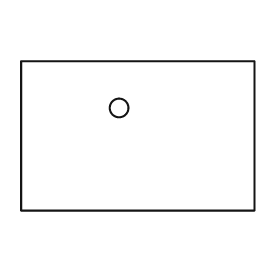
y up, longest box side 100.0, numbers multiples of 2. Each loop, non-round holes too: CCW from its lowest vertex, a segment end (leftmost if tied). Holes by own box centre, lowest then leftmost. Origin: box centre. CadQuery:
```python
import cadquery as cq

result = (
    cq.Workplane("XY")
    .moveTo(-50.0, -32.0)
    .lineTo(50.0, -32.0)
    .lineTo(50.0, 32.0)
    .lineTo(-50.0, 32.0)
    .close()
    .moveTo(-8.0, 12.0)
    .circle(4.0)
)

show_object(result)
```